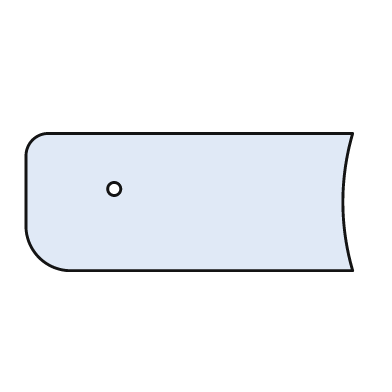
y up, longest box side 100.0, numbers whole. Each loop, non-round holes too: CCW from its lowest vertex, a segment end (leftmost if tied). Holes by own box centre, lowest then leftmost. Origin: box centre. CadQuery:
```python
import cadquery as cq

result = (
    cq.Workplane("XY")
    .moveTo(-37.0, -21.0)
    .lineTo(50.0, -21.0)
    .threePointArc((47.0, 0.0), (50.0, 21.0))
    .lineTo(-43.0, 21.0)
    .threePointArc((-48.0, 19.0), (-50.0, 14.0))
    .lineTo(-50.0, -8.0)
    .threePointArc((-46.0, -17.0), (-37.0, -21.0))
    .close()
    .moveTo(-23.0, 4.0)
    .circle(2.0)
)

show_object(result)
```